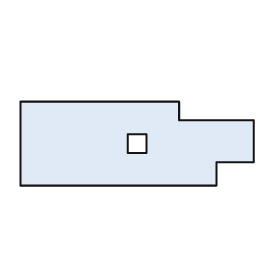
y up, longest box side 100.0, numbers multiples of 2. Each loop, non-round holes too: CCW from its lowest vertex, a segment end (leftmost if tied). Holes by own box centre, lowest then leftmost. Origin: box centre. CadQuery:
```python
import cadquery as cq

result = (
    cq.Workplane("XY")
    .moveTo(-50.0, -18.0)
    .lineTo(34.0, -18.0)
    .lineTo(34.0, -8.0)
    .lineTo(50.0, -8.0)
    .lineTo(50.0, 10.0)
    .lineTo(18.0, 10.0)
    .lineTo(18.0, 18.0)
    .lineTo(-50.0, 18.0)
    .close()
    .moveTo(-4.0, -4.0)
    .lineTo(4.0, -4.0)
    .lineTo(4.0, 4.0)
    .lineTo(-4.0, 4.0)
    .close()
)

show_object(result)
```